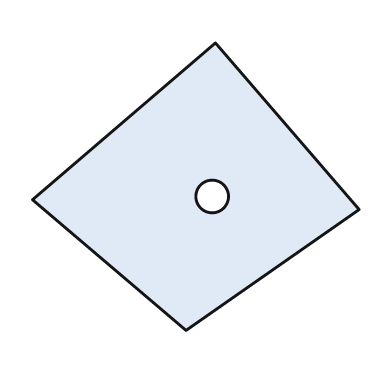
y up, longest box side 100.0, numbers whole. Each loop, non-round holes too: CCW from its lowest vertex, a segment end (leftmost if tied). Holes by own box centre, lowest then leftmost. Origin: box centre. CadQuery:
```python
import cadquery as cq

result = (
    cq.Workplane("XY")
    .moveTo(-3.0, -44.0)
    .lineTo(50.0, -7.0)
    .lineTo(6.0, 44.0)
    .lineTo(-50.0, -4.0)
    .close()
    .moveTo(5.0, -3.0)
    .circle(5.0)
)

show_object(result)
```